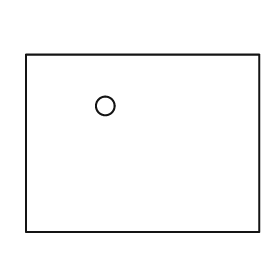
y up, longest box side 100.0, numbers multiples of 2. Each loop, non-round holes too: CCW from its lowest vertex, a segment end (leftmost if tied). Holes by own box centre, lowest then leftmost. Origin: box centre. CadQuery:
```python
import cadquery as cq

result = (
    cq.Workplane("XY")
    .moveTo(-50.0, -38.0)
    .lineTo(50.0, -38.0)
    .lineTo(50.0, 38.0)
    .lineTo(-50.0, 38.0)
    .close()
    .moveTo(-16.0, 16.0)
    .circle(4.0)
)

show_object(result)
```